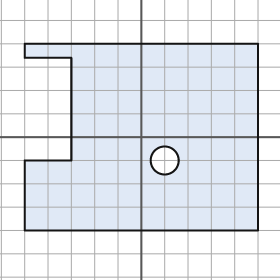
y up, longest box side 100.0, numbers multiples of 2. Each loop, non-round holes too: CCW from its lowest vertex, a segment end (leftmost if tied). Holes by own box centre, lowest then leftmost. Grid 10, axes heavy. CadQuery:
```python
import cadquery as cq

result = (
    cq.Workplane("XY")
    .moveTo(-50.0, -40.0)
    .lineTo(50.0, -40.0)
    .lineTo(50.0, 40.0)
    .lineTo(-50.0, 40.0)
    .lineTo(-50.0, 34.0)
    .lineTo(-30.0, 34.0)
    .lineTo(-30.0, -10.0)
    .lineTo(-50.0, -10.0)
    .close()
    .moveTo(10.0, -10.0)
    .circle(6.0)
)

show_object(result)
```